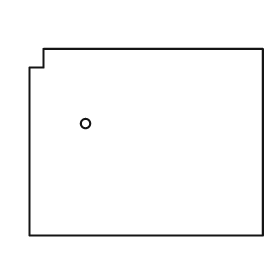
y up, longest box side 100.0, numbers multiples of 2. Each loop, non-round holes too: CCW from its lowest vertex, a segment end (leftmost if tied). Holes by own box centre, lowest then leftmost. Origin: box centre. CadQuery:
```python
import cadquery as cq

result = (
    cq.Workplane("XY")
    .moveTo(-50.0, -40.0)
    .lineTo(50.0, -40.0)
    .lineTo(50.0, 40.0)
    .lineTo(-44.0, 40.0)
    .lineTo(-44.0, 32.0)
    .lineTo(-50.0, 32.0)
    .close()
    .moveTo(-26.0, 8.0)
    .circle(2.0)
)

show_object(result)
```